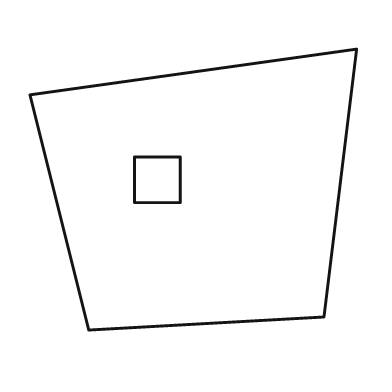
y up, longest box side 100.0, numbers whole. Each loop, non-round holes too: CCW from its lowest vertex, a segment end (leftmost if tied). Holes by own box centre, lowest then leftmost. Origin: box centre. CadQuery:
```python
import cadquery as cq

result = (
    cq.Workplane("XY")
    .moveTo(-32.0, -43.0)
    .lineTo(40.0, -39.0)
    .lineTo(50.0, 43.0)
    .lineTo(-50.0, 29.0)
    .close()
    .moveTo(-18.0, -4.0)
    .lineTo(-4.0, -4.0)
    .lineTo(-4.0, 10.0)
    .lineTo(-18.0, 10.0)
    .close()
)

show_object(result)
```